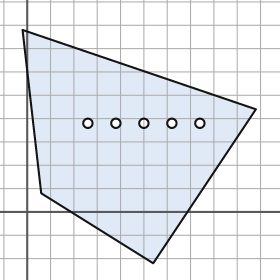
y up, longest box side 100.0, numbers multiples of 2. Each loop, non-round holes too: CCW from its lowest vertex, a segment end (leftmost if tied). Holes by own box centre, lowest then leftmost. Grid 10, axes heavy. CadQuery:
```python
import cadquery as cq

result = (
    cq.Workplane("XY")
    .moveTo(54.0, -22.0)
    .lineTo(98.0, 44.0)
    .lineTo(-2.0, 78.0)
    .lineTo(6.0, 8.0)
    .close()
    .moveTo(26.0, 38.0)
    .circle(2.0)
    .moveTo(38.0, 38.0)
    .circle(2.0)
    .moveTo(50.0, 38.0)
    .circle(2.0)
    .moveTo(62.0, 38.0)
    .circle(2.0)
    .moveTo(74.0, 38.0)
    .circle(2.0)
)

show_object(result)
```